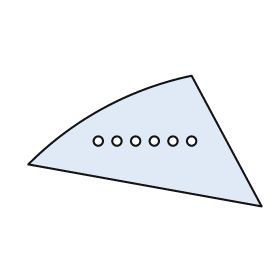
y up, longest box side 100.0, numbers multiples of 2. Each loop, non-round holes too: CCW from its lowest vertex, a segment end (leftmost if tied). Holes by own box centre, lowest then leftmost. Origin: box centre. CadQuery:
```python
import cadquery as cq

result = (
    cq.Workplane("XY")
    .moveTo(50.0, -28.0)
    .lineTo(20.0, 28.0)
    .threePointArc((-18.0, 14.0), (-50.0, -10.0))
    .close()
    .moveTo(-20.0, 0.0)
    .circle(2.0)
    .moveTo(-12.0, 0.0)
    .circle(2.0)
    .moveTo(-4.0, 0.0)
    .circle(2.0)
    .moveTo(4.0, 0.0)
    .circle(2.0)
    .moveTo(12.0, 0.0)
    .circle(2.0)
    .moveTo(20.0, 0.0)
    .circle(2.0)
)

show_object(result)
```